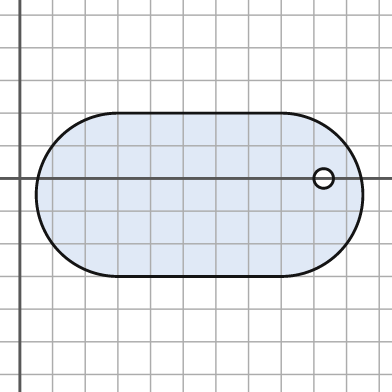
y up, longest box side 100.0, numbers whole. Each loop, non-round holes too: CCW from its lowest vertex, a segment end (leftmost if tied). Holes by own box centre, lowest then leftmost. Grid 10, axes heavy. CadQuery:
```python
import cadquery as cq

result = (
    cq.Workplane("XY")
    .moveTo(30.0, -30.0)
    .lineTo(80.0, -30.0)
    .threePointArc((105.0, -5.0), (80.0, 20.0))
    .lineTo(30.0, 20.0)
    .threePointArc((5.0, -5.0), (30.0, -30.0))
    .close()
    .moveTo(93.0, 0.0)
    .circle(3.0)
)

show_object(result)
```